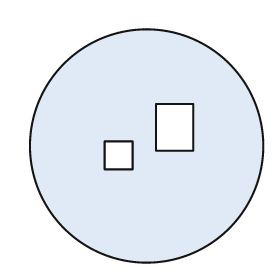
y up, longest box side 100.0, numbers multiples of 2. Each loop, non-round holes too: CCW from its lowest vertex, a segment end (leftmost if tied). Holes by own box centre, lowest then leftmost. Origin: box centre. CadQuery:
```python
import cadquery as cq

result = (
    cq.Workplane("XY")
    .moveTo(0.0, 0.0)
    .circle(50.0)
    .moveTo(-18.0, -10.0)
    .lineTo(-6.0, -10.0)
    .lineTo(-6.0, 2.0)
    .lineTo(-18.0, 2.0)
    .close()
    .moveTo(4.0, -2.0)
    .lineTo(20.0, -2.0)
    .lineTo(20.0, 18.0)
    .lineTo(4.0, 18.0)
    .close()
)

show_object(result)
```